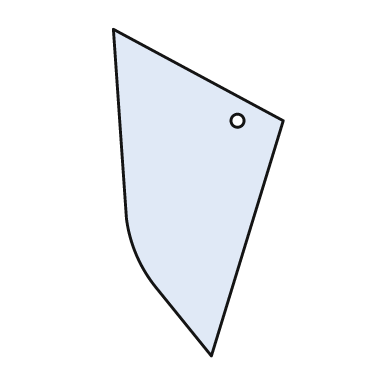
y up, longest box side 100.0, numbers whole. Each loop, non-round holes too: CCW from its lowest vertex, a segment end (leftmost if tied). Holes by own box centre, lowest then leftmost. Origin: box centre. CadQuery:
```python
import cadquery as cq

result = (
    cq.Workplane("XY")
    .moveTo(4.0, -50.0)
    .lineTo(26.0, 22.0)
    .lineTo(-26.0, 50.0)
    .lineTo(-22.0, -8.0)
    .threePointArc((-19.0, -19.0), (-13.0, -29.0))
    .close()
    .moveTo(12.0, 22.0)
    .circle(2.0)
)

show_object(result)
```